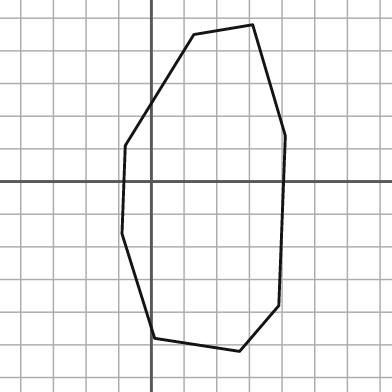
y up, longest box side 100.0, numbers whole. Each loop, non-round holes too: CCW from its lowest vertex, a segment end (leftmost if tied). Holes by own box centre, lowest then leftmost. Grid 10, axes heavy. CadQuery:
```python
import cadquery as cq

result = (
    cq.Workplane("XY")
    .moveTo(27.0, -52.0)
    .lineTo(39.0, -38.0)
    .lineTo(41.0, 14.0)
    .lineTo(31.0, 48.0)
    .lineTo(13.0, 45.0)
    .lineTo(-8.0, 11.0)
    .lineTo(-9.0, -16.0)
    .lineTo(1.0, -48.0)
    .close()
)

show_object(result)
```